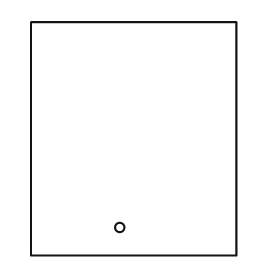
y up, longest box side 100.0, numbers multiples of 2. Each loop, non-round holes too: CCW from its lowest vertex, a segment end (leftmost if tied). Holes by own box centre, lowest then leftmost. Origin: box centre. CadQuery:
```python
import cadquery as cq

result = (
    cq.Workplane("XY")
    .moveTo(-44.0, -50.0)
    .lineTo(44.0, -50.0)
    .lineTo(44.0, 50.0)
    .lineTo(-44.0, 50.0)
    .close()
    .moveTo(-6.0, -38.0)
    .circle(2.0)
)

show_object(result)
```